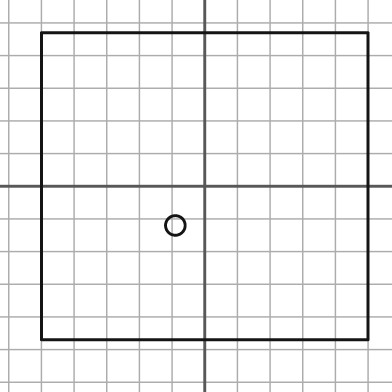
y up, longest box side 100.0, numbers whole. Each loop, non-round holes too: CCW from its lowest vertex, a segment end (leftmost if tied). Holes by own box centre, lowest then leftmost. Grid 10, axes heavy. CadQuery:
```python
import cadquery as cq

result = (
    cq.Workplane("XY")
    .moveTo(-50.0, -47.0)
    .lineTo(50.0, -47.0)
    .lineTo(50.0, 47.0)
    .lineTo(-50.0, 47.0)
    .close()
    .moveTo(-9.0, -12.0)
    .circle(3.0)
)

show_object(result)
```